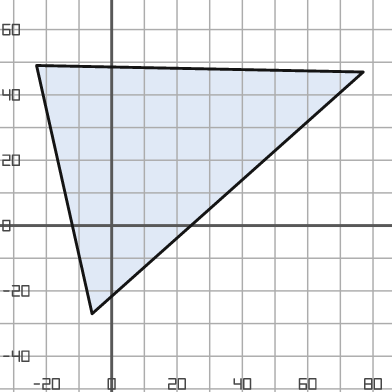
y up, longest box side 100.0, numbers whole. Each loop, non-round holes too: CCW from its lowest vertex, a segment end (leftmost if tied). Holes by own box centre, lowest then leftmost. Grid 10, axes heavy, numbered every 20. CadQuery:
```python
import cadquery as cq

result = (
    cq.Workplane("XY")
    .moveTo(-6.0, -27.0)
    .lineTo(77.0, 47.0)
    .lineTo(-23.0, 49.0)
    .close()
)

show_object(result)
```